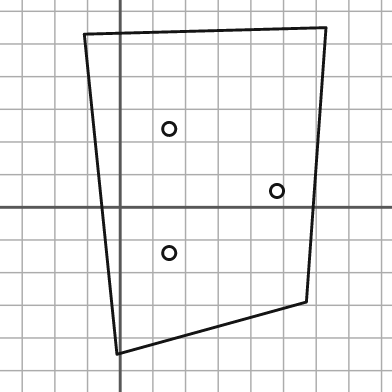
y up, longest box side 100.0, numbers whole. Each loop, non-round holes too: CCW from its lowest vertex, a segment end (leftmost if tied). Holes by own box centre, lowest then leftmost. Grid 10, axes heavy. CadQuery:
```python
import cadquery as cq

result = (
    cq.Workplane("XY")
    .moveTo(-1.0, -45.0)
    .lineTo(57.0, -29.0)
    .lineTo(63.0, 55.0)
    .lineTo(-11.0, 53.0)
    .close()
    .moveTo(15.0, -14.0)
    .circle(2.0)
    .moveTo(48.0, 5.0)
    .circle(2.0)
    .moveTo(15.0, 24.0)
    .circle(2.0)
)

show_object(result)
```